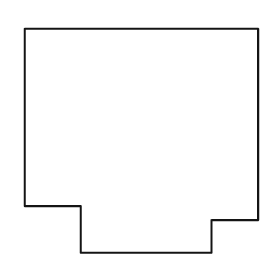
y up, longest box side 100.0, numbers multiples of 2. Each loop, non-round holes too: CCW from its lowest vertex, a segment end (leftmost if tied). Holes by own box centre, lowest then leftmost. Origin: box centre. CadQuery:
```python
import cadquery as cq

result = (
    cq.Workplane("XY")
    .moveTo(-26.0, -48.0)
    .lineTo(30.0, -48.0)
    .lineTo(30.0, -34.0)
    .lineTo(50.0, -34.0)
    .lineTo(50.0, 48.0)
    .lineTo(-50.0, 48.0)
    .lineTo(-50.0, -28.0)
    .lineTo(-26.0, -28.0)
    .close()
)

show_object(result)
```